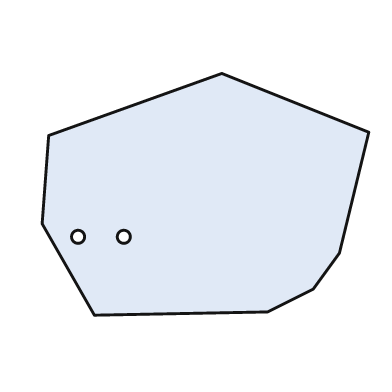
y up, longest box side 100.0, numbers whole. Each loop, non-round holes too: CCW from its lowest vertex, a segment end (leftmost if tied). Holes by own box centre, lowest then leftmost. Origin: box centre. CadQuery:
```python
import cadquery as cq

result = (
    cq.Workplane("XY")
    .moveTo(-34.0, -37.0)
    .lineTo(19.0, -36.0)
    .lineTo(33.0, -29.0)
    .lineTo(41.0, -18.0)
    .lineTo(50.0, 19.0)
    .lineTo(5.0, 37.0)
    .lineTo(-48.0, 18.0)
    .lineTo(-50.0, -9.0)
    .close()
    .moveTo(-39.0, -13.0)
    .circle(2.0)
    .moveTo(-25.0, -13.0)
    .circle(2.0)
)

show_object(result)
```